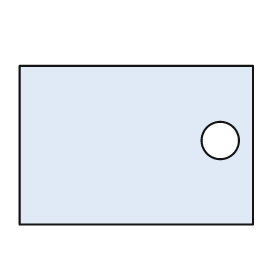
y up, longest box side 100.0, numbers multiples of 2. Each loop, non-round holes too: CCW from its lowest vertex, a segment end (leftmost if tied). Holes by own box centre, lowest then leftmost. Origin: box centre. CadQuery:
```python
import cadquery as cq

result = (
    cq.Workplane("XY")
    .moveTo(-50.0, -34.0)
    .lineTo(50.0, -34.0)
    .lineTo(50.0, 34.0)
    .lineTo(-50.0, 34.0)
    .close()
    .moveTo(36.0, 2.0)
    .circle(8.0)
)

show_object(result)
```